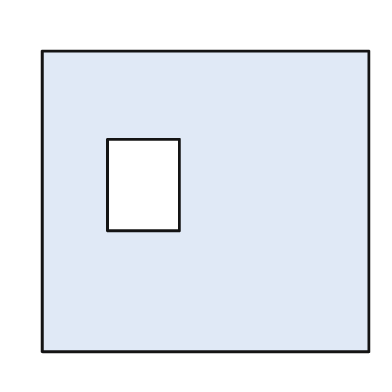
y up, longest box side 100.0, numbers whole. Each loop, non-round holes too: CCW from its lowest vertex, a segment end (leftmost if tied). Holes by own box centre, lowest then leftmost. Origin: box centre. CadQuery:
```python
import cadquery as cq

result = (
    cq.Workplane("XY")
    .moveTo(-50.0, -46.0)
    .lineTo(50.0, -46.0)
    .lineTo(50.0, 46.0)
    .lineTo(-50.0, 46.0)
    .close()
    .moveTo(-30.0, -9.0)
    .lineTo(-8.0, -9.0)
    .lineTo(-8.0, 19.0)
    .lineTo(-30.0, 19.0)
    .close()
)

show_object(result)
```